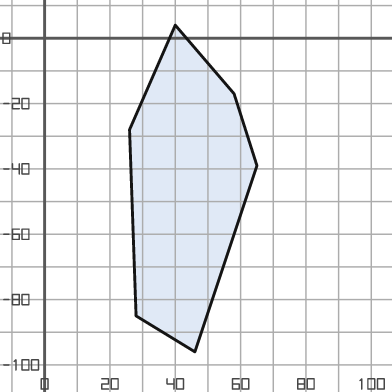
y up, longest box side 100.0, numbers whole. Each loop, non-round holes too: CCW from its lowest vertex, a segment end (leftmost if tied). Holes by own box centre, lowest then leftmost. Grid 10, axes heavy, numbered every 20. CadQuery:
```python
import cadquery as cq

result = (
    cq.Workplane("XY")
    .moveTo(46.0, -96.0)
    .lineTo(65.0, -39.0)
    .lineTo(58.0, -17.0)
    .lineTo(40.0, 4.0)
    .lineTo(26.0, -28.0)
    .lineTo(28.0, -85.0)
    .close()
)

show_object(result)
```